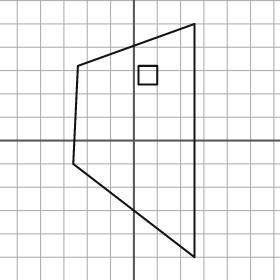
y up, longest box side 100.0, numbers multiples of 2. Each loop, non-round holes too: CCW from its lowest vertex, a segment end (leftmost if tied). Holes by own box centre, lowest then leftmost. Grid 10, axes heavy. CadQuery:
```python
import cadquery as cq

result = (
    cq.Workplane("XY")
    .moveTo(26.0, -50.0)
    .lineTo(26.0, 50.0)
    .lineTo(-24.0, 32.0)
    .lineTo(-26.0, -10.0)
    .close()
    .moveTo(2.0, 24.0)
    .lineTo(10.0, 24.0)
    .lineTo(10.0, 32.0)
    .lineTo(2.0, 32.0)
    .close()
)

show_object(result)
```